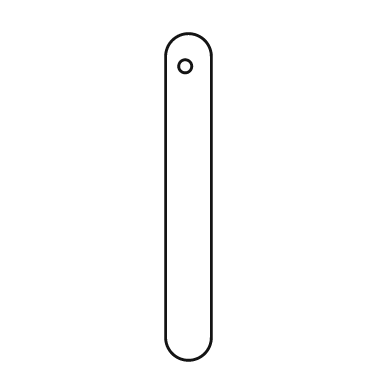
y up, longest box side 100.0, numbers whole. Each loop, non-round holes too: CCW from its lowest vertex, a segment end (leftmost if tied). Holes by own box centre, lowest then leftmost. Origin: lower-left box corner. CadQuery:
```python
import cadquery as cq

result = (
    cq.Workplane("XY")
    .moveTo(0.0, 7.0)
    .threePointArc((7.0, 0.0), (14.0, 7.0))
    .lineTo(14.0, 93.0)
    .threePointArc((7.0, 100.0), (0.0, 93.0))
    .close()
    .moveTo(6.0, 90.0)
    .circle(2.0)
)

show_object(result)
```